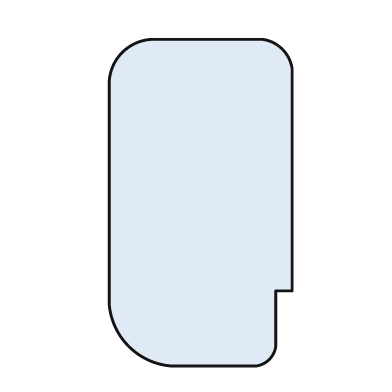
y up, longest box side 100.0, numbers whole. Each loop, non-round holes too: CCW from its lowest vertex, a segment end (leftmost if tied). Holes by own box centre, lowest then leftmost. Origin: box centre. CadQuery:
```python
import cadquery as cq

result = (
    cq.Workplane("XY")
    .moveTo(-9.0, -50.0)
    .lineTo(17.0, -50.0)
    .threePointArc((21.0, -48.0), (23.0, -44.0))
    .lineTo(23.0, -27.0)
    .lineTo(28.0, -27.0)
    .lineTo(28.0, 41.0)
    .threePointArc((25.0, 47.0), (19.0, 50.0))
    .lineTo(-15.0, 50.0)
    .threePointArc((-24.0, 46.0), (-28.0, 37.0))
    .lineTo(-28.0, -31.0)
    .threePointArc((-22.0, -44.0), (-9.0, -50.0))
    .close()
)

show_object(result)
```